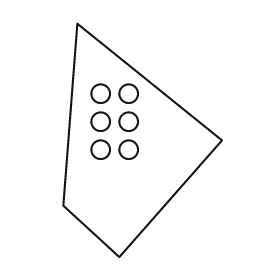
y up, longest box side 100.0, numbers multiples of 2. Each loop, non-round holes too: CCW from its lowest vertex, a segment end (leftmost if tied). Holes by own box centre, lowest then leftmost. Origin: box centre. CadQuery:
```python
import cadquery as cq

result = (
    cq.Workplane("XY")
    .moveTo(-10.0, -50.0)
    .lineTo(34.0, 0.0)
    .lineTo(-28.0, 50.0)
    .lineTo(-34.0, -28.0)
    .close()
    .moveTo(-18.0, -4.0)
    .circle(4.0)
    .moveTo(-6.0, -4.0)
    .circle(4.0)
    .moveTo(-18.0, 8.0)
    .circle(4.0)
    .moveTo(-6.0, 8.0)
    .circle(4.0)
    .moveTo(-18.0, 20.0)
    .circle(4.0)
    .moveTo(-6.0, 20.0)
    .circle(4.0)
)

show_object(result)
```